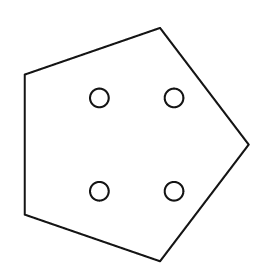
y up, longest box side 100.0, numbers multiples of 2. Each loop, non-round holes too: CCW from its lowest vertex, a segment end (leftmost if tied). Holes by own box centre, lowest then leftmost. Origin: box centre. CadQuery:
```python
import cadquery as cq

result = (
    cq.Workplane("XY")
    .moveTo(10.0, -50.0)
    .lineTo(48.0, 0.0)
    .lineTo(10.0, 50.0)
    .lineTo(-48.0, 30.0)
    .lineTo(-48.0, -30.0)
    .close()
    .moveTo(-16.0, -20.0)
    .circle(4.0)
    .moveTo(16.0, -20.0)
    .circle(4.0)
    .moveTo(-16.0, 20.0)
    .circle(4.0)
    .moveTo(16.0, 20.0)
    .circle(4.0)
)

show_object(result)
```